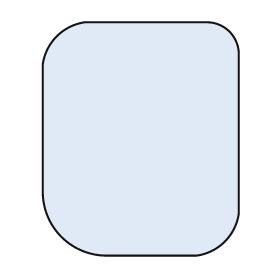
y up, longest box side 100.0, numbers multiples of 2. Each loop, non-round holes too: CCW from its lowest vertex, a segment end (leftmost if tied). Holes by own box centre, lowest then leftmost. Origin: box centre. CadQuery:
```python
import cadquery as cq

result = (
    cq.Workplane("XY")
    .moveTo(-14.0, -50.0)
    .lineTo(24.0, -50.0)
    .threePointArc((36.0, -44.0), (42.0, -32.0))
    .lineTo(42.0, 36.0)
    .threePointArc((38.0, 46.0), (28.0, 50.0))
    .lineTo(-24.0, 50.0)
    .threePointArc((-36.0, 44.0), (-42.0, 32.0))
    .lineTo(-42.0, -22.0)
    .threePointArc((-34.0, -42.0), (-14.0, -50.0))
    .close()
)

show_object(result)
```